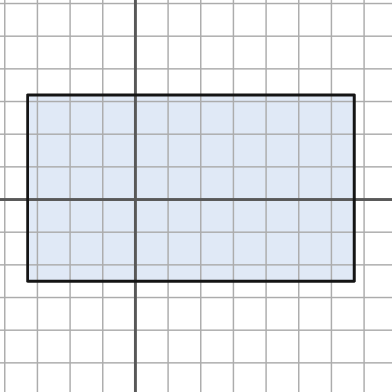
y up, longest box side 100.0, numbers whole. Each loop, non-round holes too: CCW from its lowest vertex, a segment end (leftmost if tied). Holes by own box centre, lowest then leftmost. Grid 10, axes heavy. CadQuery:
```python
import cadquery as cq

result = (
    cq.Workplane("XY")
    .moveTo(-33.0, -25.0)
    .lineTo(67.0, -25.0)
    .lineTo(67.0, 32.0)
    .lineTo(-33.0, 32.0)
    .close()
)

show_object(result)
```